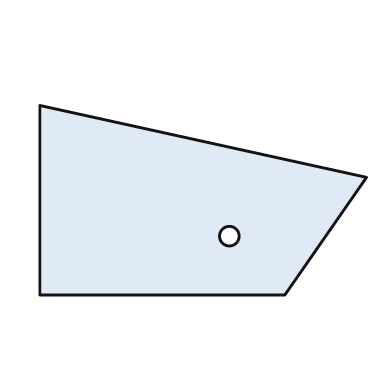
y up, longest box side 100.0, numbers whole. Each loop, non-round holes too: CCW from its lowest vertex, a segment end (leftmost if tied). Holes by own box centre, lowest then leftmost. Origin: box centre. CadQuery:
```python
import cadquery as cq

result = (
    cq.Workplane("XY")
    .moveTo(-50.0, -29.0)
    .lineTo(25.0, -29.0)
    .lineTo(50.0, 7.0)
    .lineTo(-50.0, 29.0)
    .close()
    .moveTo(8.0, -11.0)
    .circle(3.0)
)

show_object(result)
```